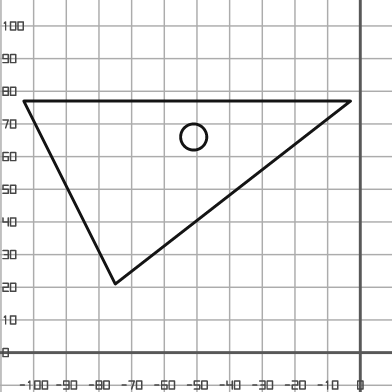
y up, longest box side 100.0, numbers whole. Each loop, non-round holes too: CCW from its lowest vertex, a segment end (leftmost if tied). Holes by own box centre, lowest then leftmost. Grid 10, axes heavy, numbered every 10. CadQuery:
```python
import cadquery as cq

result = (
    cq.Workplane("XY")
    .moveTo(-75.0, 21.0)
    .lineTo(-3.0, 77.0)
    .lineTo(-103.0, 77.0)
    .close()
    .moveTo(-51.0, 66.0)
    .circle(4.0)
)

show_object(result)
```